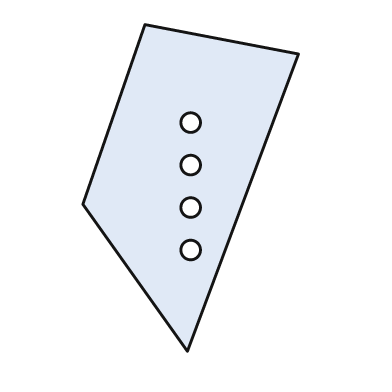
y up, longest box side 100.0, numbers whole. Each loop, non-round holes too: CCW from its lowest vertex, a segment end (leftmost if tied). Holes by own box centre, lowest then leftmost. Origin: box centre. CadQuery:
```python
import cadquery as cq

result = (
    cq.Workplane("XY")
    .moveTo(-1.0, -50.0)
    .lineTo(33.0, 41.0)
    .lineTo(-14.0, 50.0)
    .lineTo(-33.0, -5.0)
    .close()
    .moveTo(0.0, -19.0)
    .circle(3.0)
    .moveTo(0.0, -6.0)
    .circle(3.0)
    .moveTo(0.0, 7.0)
    .circle(3.0)
    .moveTo(0.0, 20.0)
    .circle(3.0)
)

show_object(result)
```